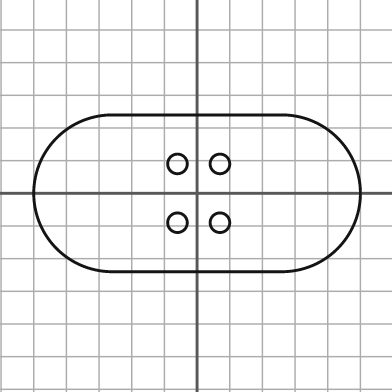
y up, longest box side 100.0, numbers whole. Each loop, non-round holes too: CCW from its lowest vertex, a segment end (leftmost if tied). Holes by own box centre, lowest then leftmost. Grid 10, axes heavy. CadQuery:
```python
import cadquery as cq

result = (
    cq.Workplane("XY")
    .moveTo(-26.0, -24.0)
    .lineTo(26.0, -24.0)
    .threePointArc((50.0, 0.0), (26.0, 24.0))
    .lineTo(-26.0, 24.0)
    .threePointArc((-50.0, 0.0), (-26.0, -24.0))
    .close()
    .moveTo(-6.0, -9.0)
    .circle(3.0)
    .moveTo(7.0, -9.0)
    .circle(3.0)
    .moveTo(-6.0, 9.0)
    .circle(3.0)
    .moveTo(7.0, 9.0)
    .circle(3.0)
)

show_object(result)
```